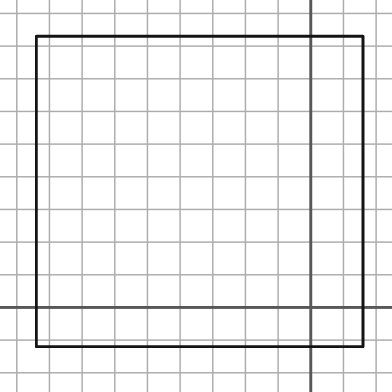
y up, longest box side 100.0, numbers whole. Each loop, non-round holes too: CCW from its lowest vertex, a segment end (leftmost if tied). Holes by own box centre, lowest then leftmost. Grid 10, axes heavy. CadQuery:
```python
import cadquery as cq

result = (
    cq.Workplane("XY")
    .moveTo(-84.0, -12.0)
    .lineTo(16.0, -12.0)
    .lineTo(16.0, 83.0)
    .lineTo(-84.0, 83.0)
    .close()
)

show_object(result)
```